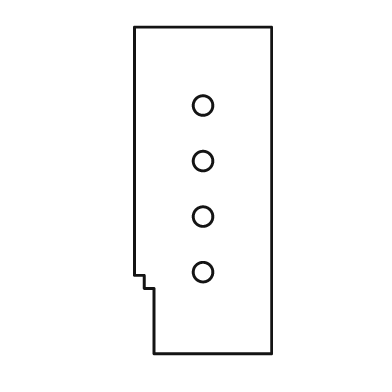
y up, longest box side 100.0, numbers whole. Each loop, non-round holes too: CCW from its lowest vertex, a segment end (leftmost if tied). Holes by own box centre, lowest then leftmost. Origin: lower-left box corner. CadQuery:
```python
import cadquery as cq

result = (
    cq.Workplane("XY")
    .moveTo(6.0, 0.0)
    .lineTo(42.0, 0.0)
    .lineTo(42.0, 100.0)
    .lineTo(0.0, 100.0)
    .lineTo(0.0, 24.0)
    .lineTo(3.0, 24.0)
    .lineTo(3.0, 20.0)
    .lineTo(6.0, 20.0)
    .close()
    .moveTo(21.0, 25.0)
    .circle(3.0)
    .moveTo(21.0, 42.0)
    .circle(3.0)
    .moveTo(21.0, 59.0)
    .circle(3.0)
    .moveTo(21.0, 76.0)
    .circle(3.0)
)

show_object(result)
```